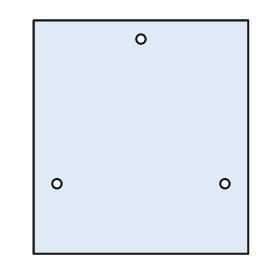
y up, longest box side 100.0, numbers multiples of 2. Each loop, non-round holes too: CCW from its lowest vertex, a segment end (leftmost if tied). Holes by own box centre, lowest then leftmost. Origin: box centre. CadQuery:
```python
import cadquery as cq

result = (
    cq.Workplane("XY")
    .moveTo(-46.0, -50.0)
    .lineTo(46.0, -50.0)
    .lineTo(46.0, 50.0)
    .lineTo(-46.0, 50.0)
    .close()
    .moveTo(-36.0, -20.0)
    .circle(2.0)
    .moveTo(36.0, -20.0)
    .circle(2.0)
    .moveTo(0.0, 42.0)
    .circle(2.0)
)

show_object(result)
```